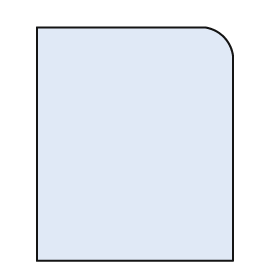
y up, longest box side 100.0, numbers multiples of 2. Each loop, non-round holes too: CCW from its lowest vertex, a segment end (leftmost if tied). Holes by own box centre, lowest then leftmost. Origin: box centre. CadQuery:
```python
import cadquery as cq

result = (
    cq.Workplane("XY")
    .moveTo(-42.0, -50.0)
    .lineTo(42.0, -50.0)
    .lineTo(42.0, 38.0)
    .threePointArc((38.0, 46.0), (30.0, 50.0))
    .lineTo(-42.0, 50.0)
    .close()
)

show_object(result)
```